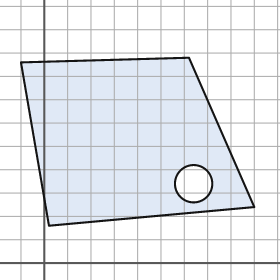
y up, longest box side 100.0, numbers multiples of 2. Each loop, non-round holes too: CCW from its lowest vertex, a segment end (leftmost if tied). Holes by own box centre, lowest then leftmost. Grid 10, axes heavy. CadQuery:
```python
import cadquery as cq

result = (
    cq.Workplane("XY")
    .moveTo(2.0, 16.0)
    .lineTo(90.0, 24.0)
    .lineTo(62.0, 88.0)
    .lineTo(-10.0, 86.0)
    .close()
    .moveTo(64.0, 34.0)
    .circle(8.0)
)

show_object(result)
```